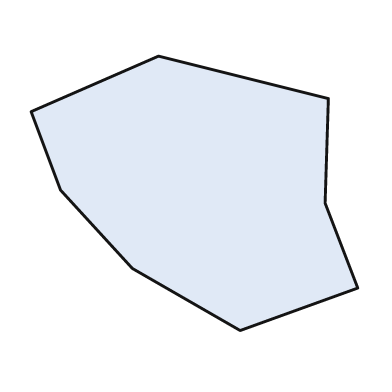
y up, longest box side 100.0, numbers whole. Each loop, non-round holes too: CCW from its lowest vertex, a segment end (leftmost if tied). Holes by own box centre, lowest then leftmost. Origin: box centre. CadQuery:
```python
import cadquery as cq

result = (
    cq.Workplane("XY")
    .moveTo(14.0, -42.0)
    .lineTo(50.0, -29.0)
    .lineTo(40.0, -3.0)
    .lineTo(41.0, 29.0)
    .lineTo(-11.0, 42.0)
    .lineTo(-50.0, 25.0)
    .lineTo(-41.0, 1.0)
    .lineTo(-19.0, -23.0)
    .close()
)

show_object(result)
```